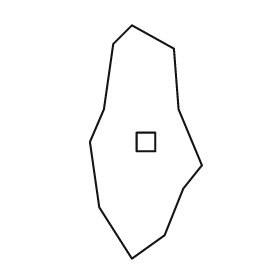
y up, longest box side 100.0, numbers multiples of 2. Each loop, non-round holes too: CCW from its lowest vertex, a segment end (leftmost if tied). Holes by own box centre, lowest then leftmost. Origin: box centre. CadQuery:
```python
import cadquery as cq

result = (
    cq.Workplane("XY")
    .moveTo(-6.0, -50.0)
    .lineTo(8.0, -40.0)
    .lineTo(16.0, -20.0)
    .lineTo(24.0, -10.0)
    .lineTo(14.0, 14.0)
    .lineTo(12.0, 40.0)
    .lineTo(-6.0, 50.0)
    .lineTo(-14.0, 42.0)
    .lineTo(-18.0, 14.0)
    .lineTo(-24.0, 0.0)
    .lineTo(-20.0, -28.0)
    .close()
    .moveTo(-4.0, -4.0)
    .lineTo(4.0, -4.0)
    .lineTo(4.0, 4.0)
    .lineTo(-4.0, 4.0)
    .close()
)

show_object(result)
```